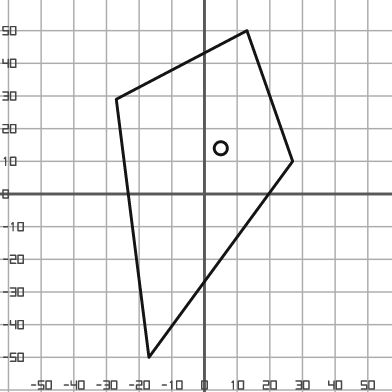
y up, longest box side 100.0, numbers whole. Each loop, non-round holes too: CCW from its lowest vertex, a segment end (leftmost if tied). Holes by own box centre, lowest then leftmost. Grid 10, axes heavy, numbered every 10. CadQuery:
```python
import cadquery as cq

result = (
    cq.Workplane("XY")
    .moveTo(-17.0, -50.0)
    .lineTo(27.0, 10.0)
    .lineTo(13.0, 50.0)
    .lineTo(-27.0, 29.0)
    .close()
    .moveTo(5.0, 14.0)
    .circle(2.0)
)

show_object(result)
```